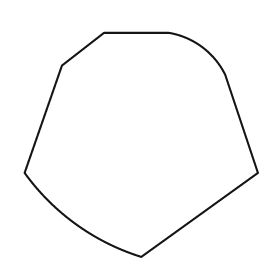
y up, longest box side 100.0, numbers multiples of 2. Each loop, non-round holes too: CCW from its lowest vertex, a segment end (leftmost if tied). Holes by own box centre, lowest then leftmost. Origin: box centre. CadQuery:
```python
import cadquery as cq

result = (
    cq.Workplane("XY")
    .moveTo(0.0, -48.0)
    .lineTo(50.0, -12.0)
    .lineTo(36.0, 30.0)
    .threePointArc((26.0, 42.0), (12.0, 48.0))
    .lineTo(-16.0, 48.0)
    .lineTo(-34.0, 34.0)
    .lineTo(-50.0, -12.0)
    .threePointArc((-28.0, -34.0), (0.0, -48.0))
    .close()
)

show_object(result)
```